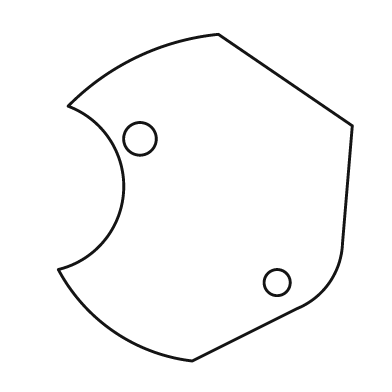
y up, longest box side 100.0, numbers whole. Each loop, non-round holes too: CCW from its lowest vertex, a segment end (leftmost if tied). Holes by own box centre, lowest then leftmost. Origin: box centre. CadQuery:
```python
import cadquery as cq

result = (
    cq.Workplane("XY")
    .moveTo(-4.0, -50.0)
    .lineTo(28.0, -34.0)
    .threePointArc((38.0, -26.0), (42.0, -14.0))
    .lineTo(45.0, 22.0)
    .lineTo(4.0, 50.0)
    .threePointArc((-21.0, 43.0), (-42.0, 28.0))
    .threePointArc((-25.0, 2.0), (-45.0, -22.0))
    .threePointArc((-28.0, -41.0), (-4.0, -50.0))
    .close()
    .moveTo(22.0, -26.0)
    .circle(4.0)
    .moveTo(-20.0, 18.0)
    .circle(5.0)
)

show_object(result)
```